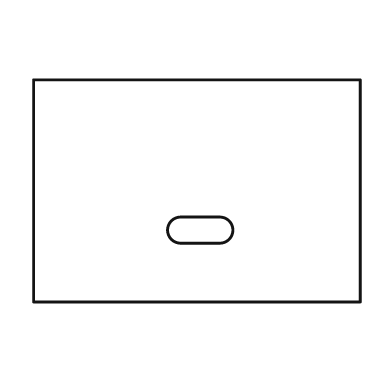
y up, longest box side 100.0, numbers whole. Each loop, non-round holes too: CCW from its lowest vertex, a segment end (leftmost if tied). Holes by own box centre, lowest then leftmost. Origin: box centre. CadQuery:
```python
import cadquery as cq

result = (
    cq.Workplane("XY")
    .moveTo(-50.0, -34.0)
    .lineTo(50.0, -34.0)
    .lineTo(50.0, 34.0)
    .lineTo(-50.0, 34.0)
    .close()
    .moveTo(-5.0, -16.0)
    .lineTo(7.0, -16.0)
    .threePointArc((11.0, -12.0), (7.0, -8.0))
    .lineTo(-5.0, -8.0)
    .threePointArc((-9.0, -12.0), (-5.0, -16.0))
    .close()
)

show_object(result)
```